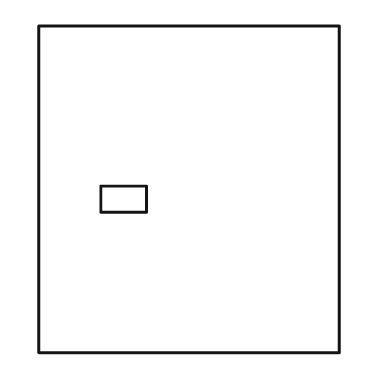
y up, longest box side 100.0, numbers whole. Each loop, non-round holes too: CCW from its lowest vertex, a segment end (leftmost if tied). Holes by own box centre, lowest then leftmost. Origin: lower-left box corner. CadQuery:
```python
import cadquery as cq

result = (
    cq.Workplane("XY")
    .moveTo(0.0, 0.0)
    .lineTo(92.0, 0.0)
    .lineTo(92.0, 100.0)
    .lineTo(0.0, 100.0)
    .close()
    .moveTo(19.0, 43.0)
    .lineTo(33.0, 43.0)
    .lineTo(33.0, 51.0)
    .lineTo(19.0, 51.0)
    .close()
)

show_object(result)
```